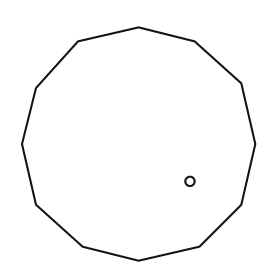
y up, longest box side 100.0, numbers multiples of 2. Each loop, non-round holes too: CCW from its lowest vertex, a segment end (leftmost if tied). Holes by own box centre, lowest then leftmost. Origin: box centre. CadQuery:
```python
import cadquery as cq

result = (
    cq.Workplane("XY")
    .moveTo(0.0, -50.0)
    .lineTo(26.0, -44.0)
    .lineTo(44.0, -26.0)
    .lineTo(50.0, 0.0)
    .lineTo(44.0, 26.0)
    .lineTo(24.0, 44.0)
    .lineTo(0.0, 50.0)
    .lineTo(-26.0, 44.0)
    .lineTo(-44.0, 24.0)
    .lineTo(-50.0, 0.0)
    .lineTo(-44.0, -26.0)
    .lineTo(-24.0, -44.0)
    .close()
    .moveTo(22.0, -16.0)
    .circle(2.0)
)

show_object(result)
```